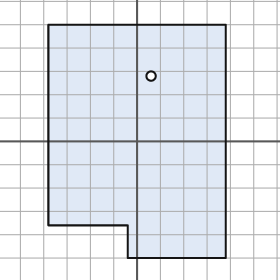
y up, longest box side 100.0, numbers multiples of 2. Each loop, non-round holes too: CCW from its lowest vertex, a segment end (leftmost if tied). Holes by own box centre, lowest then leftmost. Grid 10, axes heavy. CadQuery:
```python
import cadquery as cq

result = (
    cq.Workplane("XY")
    .moveTo(-4.0, -50.0)
    .lineTo(38.0, -50.0)
    .lineTo(38.0, 50.0)
    .lineTo(-38.0, 50.0)
    .lineTo(-38.0, -36.0)
    .lineTo(-4.0, -36.0)
    .close()
    .moveTo(6.0, 28.0)
    .circle(2.0)
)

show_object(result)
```